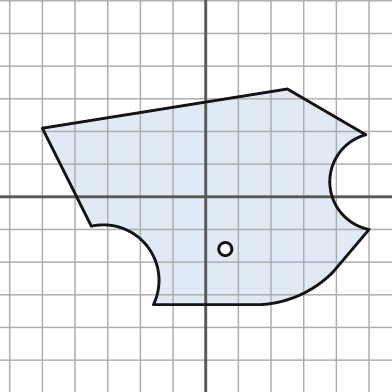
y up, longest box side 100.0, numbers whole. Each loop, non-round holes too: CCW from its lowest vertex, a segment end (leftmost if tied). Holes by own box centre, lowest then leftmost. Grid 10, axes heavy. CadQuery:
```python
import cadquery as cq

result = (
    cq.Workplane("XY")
    .moveTo(-16.0, -33.0)
    .lineTo(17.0, -33.0)
    .threePointArc((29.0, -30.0), (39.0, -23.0))
    .lineTo(50.0, -10.0)
    .threePointArc((38.0, 4.0), (49.0, 19.0))
    .lineTo(25.0, 33.0)
    .lineTo(-50.0, 21.0)
    .lineTo(-35.0, -9.0)
    .threePointArc((-18.0, -15.0), (-16.0, -33.0))
    .close()
    .moveTo(6.0, -16.0)
    .circle(2.0)
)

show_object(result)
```